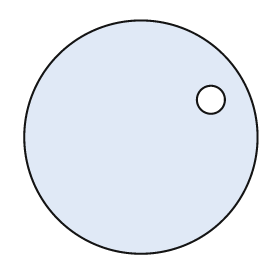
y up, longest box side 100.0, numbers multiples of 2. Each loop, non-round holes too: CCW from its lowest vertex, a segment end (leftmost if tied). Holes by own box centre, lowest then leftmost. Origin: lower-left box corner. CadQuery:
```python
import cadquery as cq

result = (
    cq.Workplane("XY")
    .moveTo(50.0, 50.0)
    .circle(50.0)
    .moveTo(80.0, 66.0)
    .circle(6.0)
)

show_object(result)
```